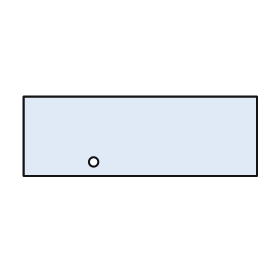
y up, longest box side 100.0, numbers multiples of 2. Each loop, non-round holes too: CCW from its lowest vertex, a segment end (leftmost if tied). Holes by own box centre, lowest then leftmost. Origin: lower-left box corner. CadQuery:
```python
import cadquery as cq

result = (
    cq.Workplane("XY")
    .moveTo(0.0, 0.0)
    .lineTo(100.0, 0.0)
    .lineTo(100.0, 34.0)
    .lineTo(0.0, 34.0)
    .close()
    .moveTo(30.0, 6.0)
    .circle(2.0)
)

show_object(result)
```